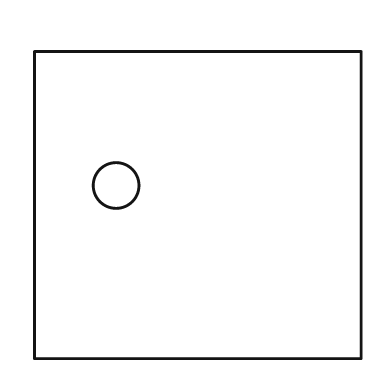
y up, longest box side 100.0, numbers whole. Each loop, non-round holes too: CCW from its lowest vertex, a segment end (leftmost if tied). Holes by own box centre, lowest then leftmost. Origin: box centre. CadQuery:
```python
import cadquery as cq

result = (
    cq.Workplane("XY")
    .moveTo(-50.0, -47.0)
    .lineTo(50.0, -47.0)
    .lineTo(50.0, 47.0)
    .lineTo(-50.0, 47.0)
    .close()
    .moveTo(-25.0, 6.0)
    .circle(7.0)
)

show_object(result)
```